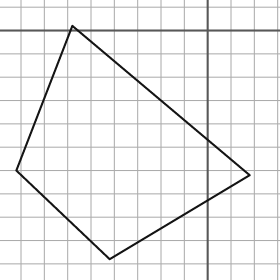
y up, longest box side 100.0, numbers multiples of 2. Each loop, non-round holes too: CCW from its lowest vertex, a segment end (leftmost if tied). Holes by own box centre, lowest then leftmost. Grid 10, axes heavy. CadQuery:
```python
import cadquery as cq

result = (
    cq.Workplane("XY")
    .moveTo(-42.0, -98.0)
    .lineTo(18.0, -62.0)
    .lineTo(-58.0, 2.0)
    .lineTo(-82.0, -60.0)
    .close()
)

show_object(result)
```